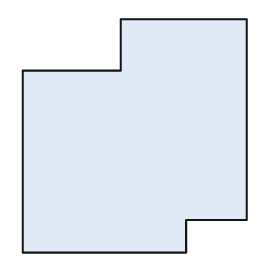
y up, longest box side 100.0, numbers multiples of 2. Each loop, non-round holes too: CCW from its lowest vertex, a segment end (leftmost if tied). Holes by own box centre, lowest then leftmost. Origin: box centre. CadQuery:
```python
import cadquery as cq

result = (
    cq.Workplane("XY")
    .moveTo(-48.0, -50.0)
    .lineTo(22.0, -50.0)
    .lineTo(22.0, -36.0)
    .lineTo(48.0, -36.0)
    .lineTo(48.0, 50.0)
    .lineTo(-6.0, 50.0)
    .lineTo(-6.0, 28.0)
    .lineTo(-48.0, 28.0)
    .close()
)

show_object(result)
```